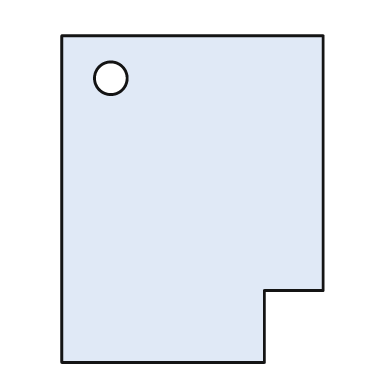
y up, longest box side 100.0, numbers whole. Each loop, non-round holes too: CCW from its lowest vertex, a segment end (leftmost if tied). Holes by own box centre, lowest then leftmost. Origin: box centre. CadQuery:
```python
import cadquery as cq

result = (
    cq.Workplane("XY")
    .moveTo(-40.0, -50.0)
    .lineTo(22.0, -50.0)
    .lineTo(22.0, -28.0)
    .lineTo(40.0, -28.0)
    .lineTo(40.0, 50.0)
    .lineTo(-40.0, 50.0)
    .close()
    .moveTo(-25.0, 37.0)
    .circle(5.0)
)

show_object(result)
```